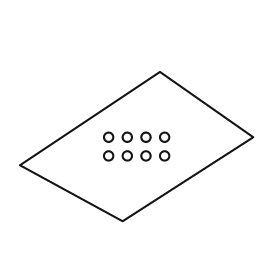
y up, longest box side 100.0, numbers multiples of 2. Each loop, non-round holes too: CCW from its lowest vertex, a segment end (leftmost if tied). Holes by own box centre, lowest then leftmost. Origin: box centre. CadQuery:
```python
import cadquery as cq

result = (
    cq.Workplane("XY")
    .moveTo(-6.0, -32.0)
    .lineTo(50.0, 4.0)
    .lineTo(10.0, 32.0)
    .lineTo(-50.0, -8.0)
    .close()
    .moveTo(-12.0, -4.0)
    .circle(2.0)
    .moveTo(-4.0, -4.0)
    .circle(2.0)
    .moveTo(4.0, -4.0)
    .circle(2.0)
    .moveTo(12.0, -4.0)
    .circle(2.0)
    .moveTo(-12.0, 4.0)
    .circle(2.0)
    .moveTo(-4.0, 4.0)
    .circle(2.0)
    .moveTo(4.0, 4.0)
    .circle(2.0)
    .moveTo(12.0, 4.0)
    .circle(2.0)
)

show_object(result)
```